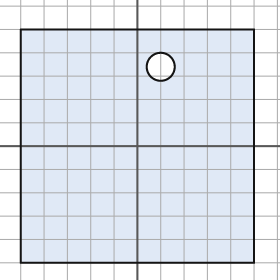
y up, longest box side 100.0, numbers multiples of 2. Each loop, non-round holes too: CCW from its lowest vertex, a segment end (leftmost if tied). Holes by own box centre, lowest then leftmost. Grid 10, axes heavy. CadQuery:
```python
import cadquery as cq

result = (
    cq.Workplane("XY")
    .moveTo(-50.0, -50.0)
    .lineTo(50.0, -50.0)
    .lineTo(50.0, 50.0)
    .lineTo(-50.0, 50.0)
    .close()
    .moveTo(10.0, 34.0)
    .circle(6.0)
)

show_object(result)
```